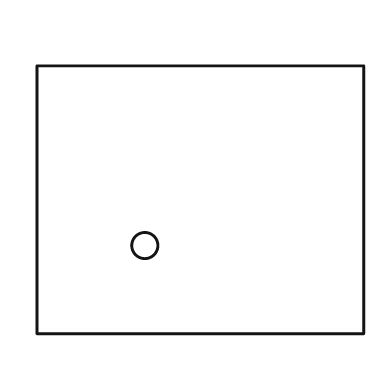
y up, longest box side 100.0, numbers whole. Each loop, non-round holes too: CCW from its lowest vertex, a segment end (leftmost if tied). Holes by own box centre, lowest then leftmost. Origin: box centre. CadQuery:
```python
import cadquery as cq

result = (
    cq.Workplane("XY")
    .moveTo(-50.0, -41.0)
    .lineTo(50.0, -41.0)
    .lineTo(50.0, 41.0)
    .lineTo(-50.0, 41.0)
    .close()
    .moveTo(-17.0, -14.0)
    .circle(4.0)
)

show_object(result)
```